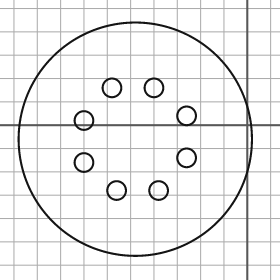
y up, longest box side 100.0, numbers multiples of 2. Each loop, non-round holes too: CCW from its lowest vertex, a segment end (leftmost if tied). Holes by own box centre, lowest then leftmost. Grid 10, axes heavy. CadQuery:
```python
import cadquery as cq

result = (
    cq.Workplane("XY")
    .moveTo(-48.0, -6.0)
    .circle(50.0)
    .moveTo(-56.0, -28.0)
    .circle(4.0)
    .moveTo(-38.0, -28.0)
    .circle(4.0)
    .moveTo(-70.0, -16.0)
    .circle(4.0)
    .moveTo(-26.0, -14.0)
    .circle(4.0)
    .moveTo(-70.0, 2.0)
    .circle(4.0)
    .moveTo(-26.0, 4.0)
    .circle(4.0)
    .moveTo(-58.0, 16.0)
    .circle(4.0)
    .moveTo(-40.0, 16.0)
    .circle(4.0)
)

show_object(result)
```